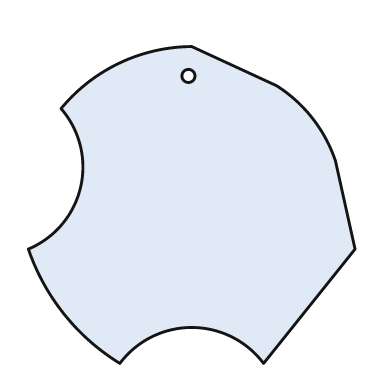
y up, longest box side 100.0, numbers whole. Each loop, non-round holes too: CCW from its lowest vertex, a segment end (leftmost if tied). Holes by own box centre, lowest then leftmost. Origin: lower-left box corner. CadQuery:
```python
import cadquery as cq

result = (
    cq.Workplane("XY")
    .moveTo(28.0, 0.0)
    .threePointArc((50.0, 11.0), (72.0, 0.0))
    .lineTo(100.0, 35.0)
    .lineTo(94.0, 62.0)
    .threePointArc((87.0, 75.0), (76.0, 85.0))
    .lineTo(50.0, 97.0)
    .threePointArc((28.0, 92.0), (10.0, 78.0))
    .threePointArc((16.0, 54.0), (0.0, 35.0))
    .threePointArc((11.0, 15.0), (28.0, 0.0))
    .close()
    .moveTo(49.0, 88.0)
    .circle(2.0)
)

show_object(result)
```